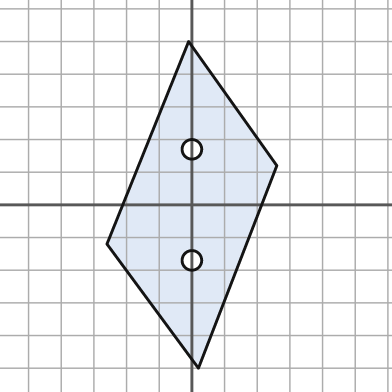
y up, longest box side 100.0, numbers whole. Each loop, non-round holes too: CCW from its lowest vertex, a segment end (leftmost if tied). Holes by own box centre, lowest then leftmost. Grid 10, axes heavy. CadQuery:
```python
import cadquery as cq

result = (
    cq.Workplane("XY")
    .moveTo(2.0, -50.0)
    .lineTo(26.0, 12.0)
    .lineTo(-1.0, 50.0)
    .lineTo(-26.0, -12.0)
    .close()
    .moveTo(0.0, -17.0)
    .circle(3.0)
    .moveTo(0.0, 17.0)
    .circle(3.0)
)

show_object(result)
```